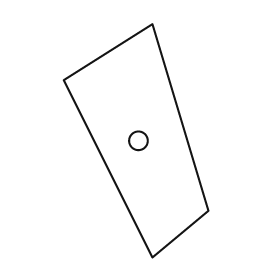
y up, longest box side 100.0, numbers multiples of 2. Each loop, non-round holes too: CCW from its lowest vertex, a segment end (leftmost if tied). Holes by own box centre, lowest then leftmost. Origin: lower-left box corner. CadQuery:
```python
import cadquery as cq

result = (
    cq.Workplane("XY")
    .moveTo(38.0, 0.0)
    .lineTo(62.0, 20.0)
    .lineTo(38.0, 100.0)
    .lineTo(0.0, 76.0)
    .close()
    .moveTo(32.0, 50.0)
    .circle(4.0)
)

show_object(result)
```